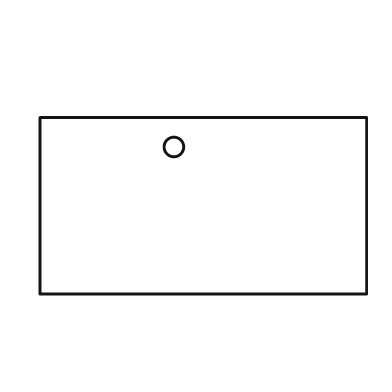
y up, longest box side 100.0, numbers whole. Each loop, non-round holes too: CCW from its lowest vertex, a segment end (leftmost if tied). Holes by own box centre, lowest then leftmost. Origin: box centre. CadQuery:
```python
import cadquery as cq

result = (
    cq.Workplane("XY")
    .moveTo(-50.0, -27.0)
    .lineTo(50.0, -27.0)
    .lineTo(50.0, 27.0)
    .lineTo(-50.0, 27.0)
    .close()
    .moveTo(-9.0, 18.0)
    .circle(3.0)
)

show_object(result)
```